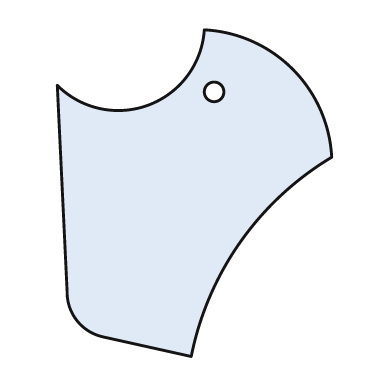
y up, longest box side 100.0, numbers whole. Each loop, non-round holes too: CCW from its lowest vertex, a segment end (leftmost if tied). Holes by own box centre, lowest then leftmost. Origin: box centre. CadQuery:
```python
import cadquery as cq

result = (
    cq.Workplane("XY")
    .moveTo(-1.0, -50.0)
    .threePointArc((14.0, -15.0), (42.0, 11.0))
    .threePointArc((30.0, 38.0), (3.0, 50.0))
    .threePointArc((-14.0, 27.0), (-42.0, 33.0))
    .lineTo(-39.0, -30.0)
    .threePointArc((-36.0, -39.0), (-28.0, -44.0))
    .close()
    .moveTo(6.0, 31.0)
    .circle(3.0)
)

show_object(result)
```